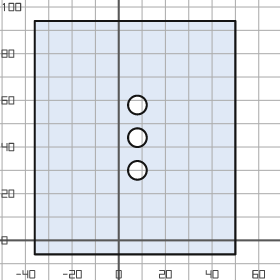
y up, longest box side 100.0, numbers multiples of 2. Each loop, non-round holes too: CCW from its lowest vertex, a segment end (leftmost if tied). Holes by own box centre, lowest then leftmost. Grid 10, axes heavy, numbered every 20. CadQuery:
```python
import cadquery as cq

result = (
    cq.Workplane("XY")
    .moveTo(-36.0, -6.0)
    .lineTo(50.0, -6.0)
    .lineTo(50.0, 94.0)
    .lineTo(-36.0, 94.0)
    .close()
    .moveTo(8.0, 30.0)
    .circle(4.0)
    .moveTo(8.0, 44.0)
    .circle(4.0)
    .moveTo(8.0, 58.0)
    .circle(4.0)
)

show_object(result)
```